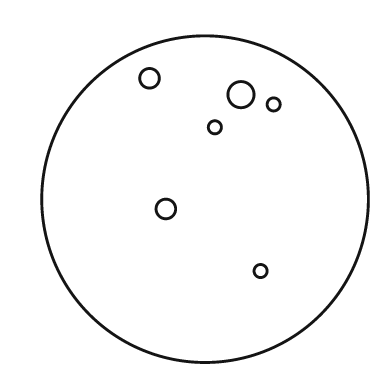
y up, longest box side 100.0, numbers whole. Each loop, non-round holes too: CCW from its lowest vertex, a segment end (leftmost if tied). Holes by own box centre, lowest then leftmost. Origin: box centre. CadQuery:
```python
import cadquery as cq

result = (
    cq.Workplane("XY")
    .moveTo(0.0, 0.0)
    .circle(50.0)
    .moveTo(17.0, -22.0)
    .circle(2.0)
    .moveTo(-12.0, -3.0)
    .circle(3.0)
    .moveTo(3.0, 22.0)
    .circle(2.0)
    .moveTo(21.0, 29.0)
    .circle(2.0)
    .moveTo(11.0, 32.0)
    .circle(4.0)
    .moveTo(-17.0, 37.0)
    .circle(3.0)
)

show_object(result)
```